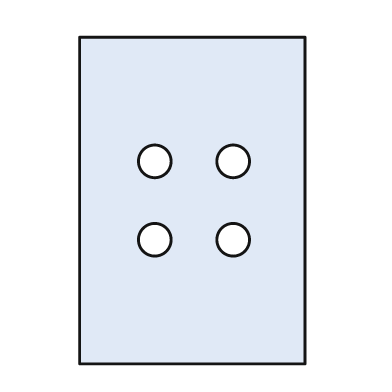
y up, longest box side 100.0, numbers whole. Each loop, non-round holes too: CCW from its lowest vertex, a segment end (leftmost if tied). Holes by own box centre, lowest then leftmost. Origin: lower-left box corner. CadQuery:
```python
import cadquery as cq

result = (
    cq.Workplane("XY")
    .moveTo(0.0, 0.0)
    .lineTo(69.0, 0.0)
    .lineTo(69.0, 100.0)
    .lineTo(0.0, 100.0)
    .close()
    .moveTo(23.0, 38.0)
    .circle(5.0)
    .moveTo(47.0, 38.0)
    .circle(5.0)
    .moveTo(23.0, 62.0)
    .circle(5.0)
    .moveTo(47.0, 62.0)
    .circle(5.0)
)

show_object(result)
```